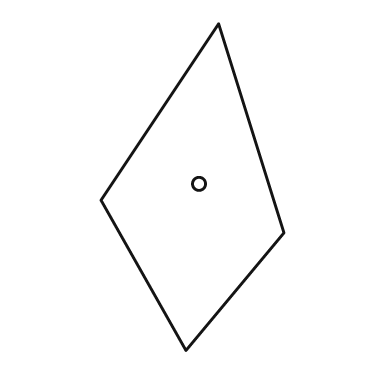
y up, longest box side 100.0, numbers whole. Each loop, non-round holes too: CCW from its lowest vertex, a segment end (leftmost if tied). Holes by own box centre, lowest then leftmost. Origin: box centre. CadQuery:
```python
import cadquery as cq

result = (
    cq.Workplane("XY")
    .moveTo(-2.0, -50.0)
    .lineTo(28.0, -14.0)
    .lineTo(8.0, 50.0)
    .lineTo(-28.0, -4.0)
    .close()
    .moveTo(2.0, 1.0)
    .circle(2.0)
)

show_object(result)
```